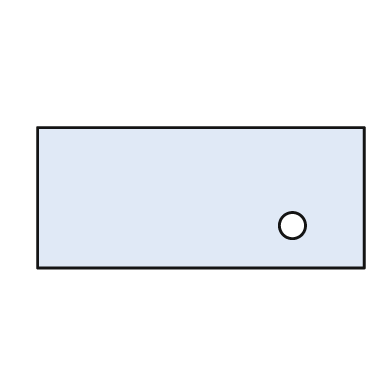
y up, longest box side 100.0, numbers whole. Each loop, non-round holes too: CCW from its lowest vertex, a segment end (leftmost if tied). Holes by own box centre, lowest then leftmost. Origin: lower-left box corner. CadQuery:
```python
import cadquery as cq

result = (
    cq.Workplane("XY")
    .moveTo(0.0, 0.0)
    .lineTo(100.0, 0.0)
    .lineTo(100.0, 43.0)
    .lineTo(0.0, 43.0)
    .close()
    .moveTo(78.0, 13.0)
    .circle(4.0)
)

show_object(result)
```